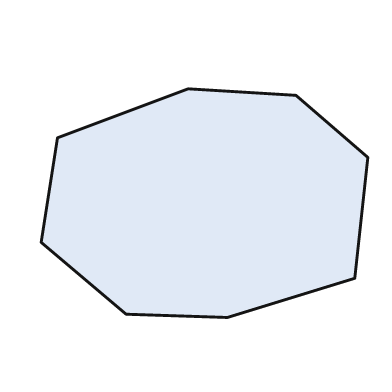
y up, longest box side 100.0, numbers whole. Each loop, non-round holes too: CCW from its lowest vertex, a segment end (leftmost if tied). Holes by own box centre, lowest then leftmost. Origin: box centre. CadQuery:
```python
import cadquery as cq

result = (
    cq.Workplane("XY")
    .moveTo(7.0, -35.0)
    .lineTo(46.0, -23.0)
    .lineTo(50.0, 14.0)
    .lineTo(28.0, 33.0)
    .lineTo(-5.0, 35.0)
    .lineTo(-45.0, 20.0)
    .lineTo(-50.0, -12.0)
    .lineTo(-24.0, -34.0)
    .close()
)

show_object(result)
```